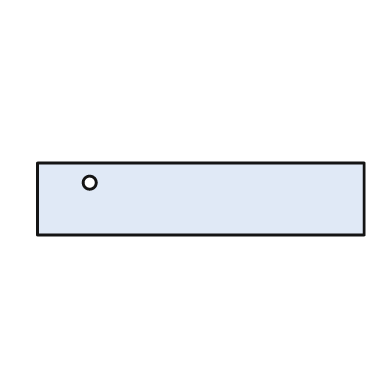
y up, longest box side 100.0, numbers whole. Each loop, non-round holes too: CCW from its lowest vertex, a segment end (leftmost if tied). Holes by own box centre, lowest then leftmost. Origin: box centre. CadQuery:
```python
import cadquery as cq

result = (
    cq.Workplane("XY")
    .moveTo(-50.0, -11.0)
    .lineTo(50.0, -11.0)
    .lineTo(50.0, 11.0)
    .lineTo(-50.0, 11.0)
    .close()
    .moveTo(-34.0, 5.0)
    .circle(2.0)
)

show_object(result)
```